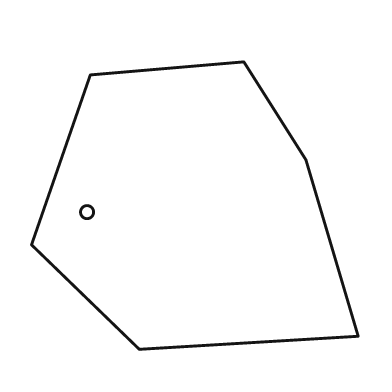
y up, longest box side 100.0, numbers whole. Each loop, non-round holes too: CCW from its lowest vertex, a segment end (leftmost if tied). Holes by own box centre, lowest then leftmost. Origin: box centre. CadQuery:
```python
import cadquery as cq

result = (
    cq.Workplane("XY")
    .moveTo(-17.0, -44.0)
    .lineTo(50.0, -40.0)
    .lineTo(34.0, 14.0)
    .lineTo(15.0, 44.0)
    .lineTo(-32.0, 40.0)
    .lineTo(-50.0, -12.0)
    .close()
    .moveTo(-33.0, -2.0)
    .circle(2.0)
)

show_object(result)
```